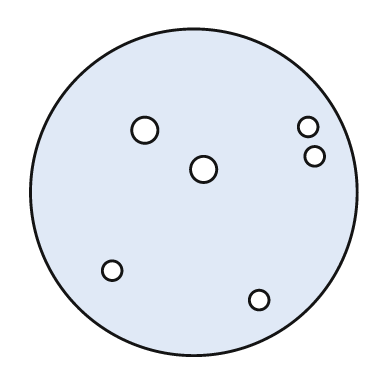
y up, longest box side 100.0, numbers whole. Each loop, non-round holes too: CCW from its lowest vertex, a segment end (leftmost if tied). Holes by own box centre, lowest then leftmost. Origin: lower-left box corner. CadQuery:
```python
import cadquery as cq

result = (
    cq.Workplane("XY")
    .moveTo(50.0, 50.0)
    .circle(50.0)
    .moveTo(70.0, 17.0)
    .circle(3.0)
    .moveTo(25.0, 26.0)
    .circle(3.0)
    .moveTo(53.0, 57.0)
    .circle(4.0)
    .moveTo(87.0, 61.0)
    .circle(3.0)
    .moveTo(35.0, 69.0)
    .circle(4.0)
    .moveTo(85.0, 70.0)
    .circle(3.0)
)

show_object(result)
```